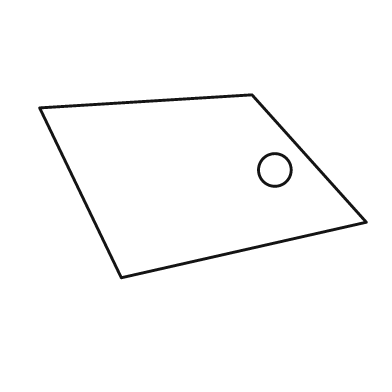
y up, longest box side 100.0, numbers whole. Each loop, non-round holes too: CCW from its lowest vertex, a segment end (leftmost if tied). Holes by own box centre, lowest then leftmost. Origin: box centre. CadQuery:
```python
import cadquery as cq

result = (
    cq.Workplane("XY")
    .moveTo(-25.0, -28.0)
    .lineTo(50.0, -11.0)
    .lineTo(15.0, 28.0)
    .lineTo(-50.0, 24.0)
    .close()
    .moveTo(22.0, 5.0)
    .circle(5.0)
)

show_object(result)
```